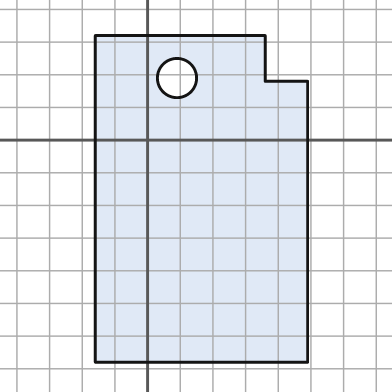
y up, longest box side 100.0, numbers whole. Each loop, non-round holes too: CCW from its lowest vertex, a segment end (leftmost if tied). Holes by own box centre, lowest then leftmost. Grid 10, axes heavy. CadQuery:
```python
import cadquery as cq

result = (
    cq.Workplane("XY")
    .moveTo(-16.0, -68.0)
    .lineTo(49.0, -68.0)
    .lineTo(49.0, 18.0)
    .lineTo(36.0, 18.0)
    .lineTo(36.0, 32.0)
    .lineTo(-16.0, 32.0)
    .close()
    .moveTo(9.0, 19.0)
    .circle(6.0)
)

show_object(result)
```